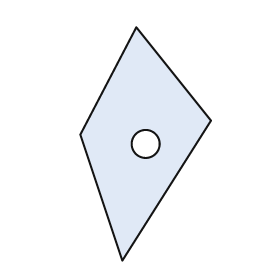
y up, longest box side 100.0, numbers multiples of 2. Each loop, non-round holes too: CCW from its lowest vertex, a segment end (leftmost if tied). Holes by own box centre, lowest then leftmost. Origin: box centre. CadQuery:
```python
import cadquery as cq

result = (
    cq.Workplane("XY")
    .moveTo(-10.0, -50.0)
    .lineTo(28.0, 10.0)
    .lineTo(-4.0, 50.0)
    .lineTo(-28.0, 4.0)
    .close()
    .moveTo(0.0, 0.0)
    .circle(6.0)
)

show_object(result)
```